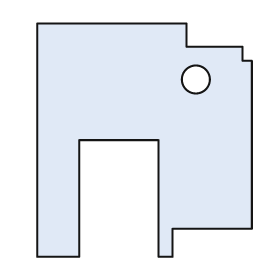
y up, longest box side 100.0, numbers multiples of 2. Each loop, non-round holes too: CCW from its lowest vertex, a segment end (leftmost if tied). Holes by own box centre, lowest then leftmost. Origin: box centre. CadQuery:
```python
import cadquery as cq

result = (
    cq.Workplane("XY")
    .moveTo(-46.0, -50.0)
    .lineTo(-28.0, -50.0)
    .lineTo(-28.0, 0.0)
    .lineTo(6.0, 0.0)
    .lineTo(6.0, -50.0)
    .lineTo(12.0, -50.0)
    .lineTo(12.0, -38.0)
    .lineTo(46.0, -38.0)
    .lineTo(46.0, 34.0)
    .lineTo(42.0, 34.0)
    .lineTo(42.0, 40.0)
    .lineTo(18.0, 40.0)
    .lineTo(18.0, 50.0)
    .lineTo(-46.0, 50.0)
    .close()
    .moveTo(22.0, 26.0)
    .circle(6.0)
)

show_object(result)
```